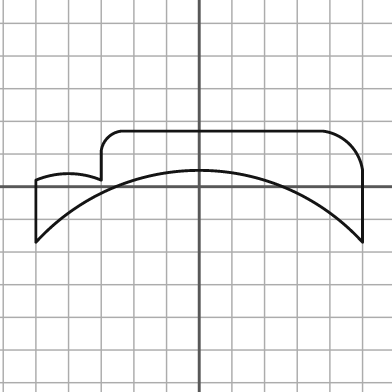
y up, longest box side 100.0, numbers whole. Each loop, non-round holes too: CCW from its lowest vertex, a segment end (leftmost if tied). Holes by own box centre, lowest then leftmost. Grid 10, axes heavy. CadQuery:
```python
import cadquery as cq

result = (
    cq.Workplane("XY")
    .moveTo(-50.0, -17.0)
    .threePointArc((0.0, 5.0), (50.0, -17.0))
    .lineTo(50.0, 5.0)
    .threePointArc((46.0, 13.0), (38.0, 17.0))
    .lineTo(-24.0, 17.0)
    .threePointArc((-28.0, 15.0), (-30.0, 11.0))
    .lineTo(-30.0, 2.0)
    .threePointArc((-40.0, 4.0), (-50.0, 2.0))
    .close()
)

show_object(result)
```